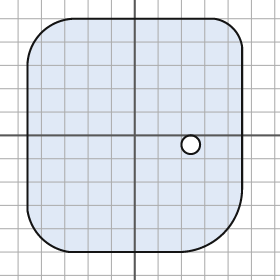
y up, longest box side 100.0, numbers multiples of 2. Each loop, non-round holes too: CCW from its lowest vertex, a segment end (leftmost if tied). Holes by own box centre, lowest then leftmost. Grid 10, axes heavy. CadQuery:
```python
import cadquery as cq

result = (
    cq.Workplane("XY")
    .moveTo(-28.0, -50.0)
    .lineTo(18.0, -50.0)
    .threePointArc((38.0, -42.0), (46.0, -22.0))
    .lineTo(46.0, 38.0)
    .threePointArc((42.0, 46.0), (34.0, 50.0))
    .lineTo(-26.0, 50.0)
    .threePointArc((-40.0, 44.0), (-46.0, 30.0))
    .lineTo(-46.0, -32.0)
    .threePointArc((-40.0, -44.0), (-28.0, -50.0))
    .close()
    .moveTo(24.0, -4.0)
    .circle(4.0)
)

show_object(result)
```